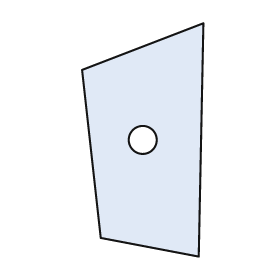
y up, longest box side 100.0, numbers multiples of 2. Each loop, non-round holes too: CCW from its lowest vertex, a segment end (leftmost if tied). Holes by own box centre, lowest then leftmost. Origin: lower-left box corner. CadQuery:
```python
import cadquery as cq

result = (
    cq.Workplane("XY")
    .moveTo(50.0, 0.0)
    .lineTo(52.0, 100.0)
    .lineTo(0.0, 80.0)
    .lineTo(8.0, 8.0)
    .close()
    .moveTo(26.0, 50.0)
    .circle(6.0)
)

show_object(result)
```